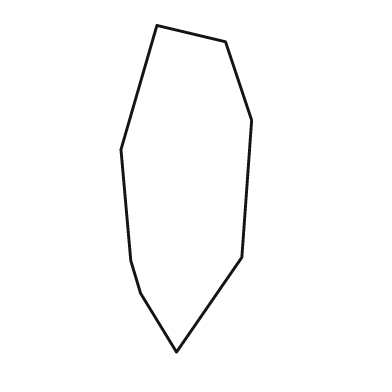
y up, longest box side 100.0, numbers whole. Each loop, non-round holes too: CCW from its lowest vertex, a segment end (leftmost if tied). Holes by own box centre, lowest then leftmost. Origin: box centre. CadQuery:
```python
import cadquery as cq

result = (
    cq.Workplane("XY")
    .moveTo(-3.0, -50.0)
    .lineTo(17.0, -21.0)
    .lineTo(20.0, 21.0)
    .lineTo(12.0, 45.0)
    .lineTo(-9.0, 50.0)
    .lineTo(-20.0, 12.0)
    .lineTo(-17.0, -22.0)
    .lineTo(-14.0, -32.0)
    .close()
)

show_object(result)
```